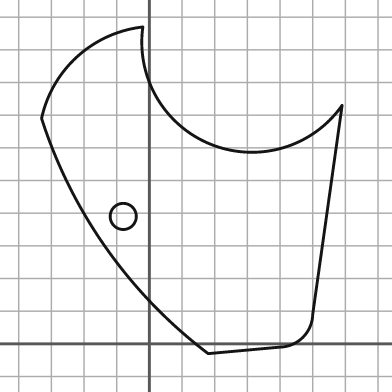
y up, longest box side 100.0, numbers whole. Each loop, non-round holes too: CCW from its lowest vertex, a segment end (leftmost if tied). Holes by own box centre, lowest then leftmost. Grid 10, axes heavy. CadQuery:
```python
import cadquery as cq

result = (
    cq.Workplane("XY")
    .moveTo(18.0, -3.0)
    .lineTo(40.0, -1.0)
    .threePointArc((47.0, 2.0), (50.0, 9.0))
    .lineTo(59.0, 73.0)
    .threePointArc((19.0, 61.0), (-2.0, 97.0))
    .threePointArc((-22.0, 88.0), (-33.0, 69.0))
    .threePointArc((-13.0, 29.0), (18.0, -3.0))
    .close()
    .moveTo(-8.0, 39.0)
    .circle(4.0)
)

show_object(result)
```